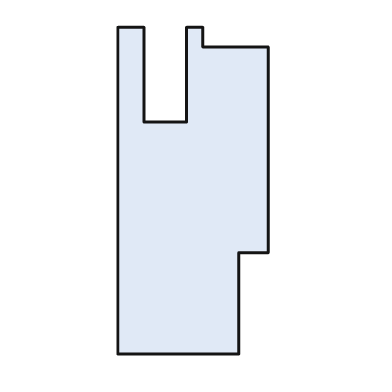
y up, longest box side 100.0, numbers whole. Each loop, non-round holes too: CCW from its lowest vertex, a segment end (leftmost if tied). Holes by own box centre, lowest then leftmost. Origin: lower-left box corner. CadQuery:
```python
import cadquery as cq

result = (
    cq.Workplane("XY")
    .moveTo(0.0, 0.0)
    .lineTo(37.0, 0.0)
    .lineTo(37.0, 31.0)
    .lineTo(46.0, 31.0)
    .lineTo(46.0, 94.0)
    .lineTo(26.0, 94.0)
    .lineTo(26.0, 100.0)
    .lineTo(21.0, 100.0)
    .lineTo(21.0, 71.0)
    .lineTo(8.0, 71.0)
    .lineTo(8.0, 100.0)
    .lineTo(0.0, 100.0)
    .close()
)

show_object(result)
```